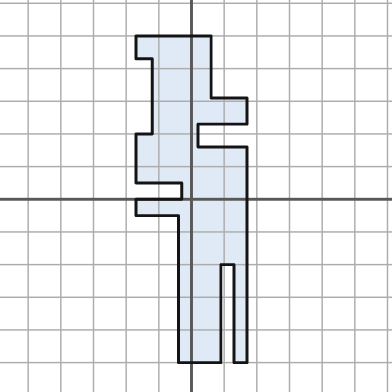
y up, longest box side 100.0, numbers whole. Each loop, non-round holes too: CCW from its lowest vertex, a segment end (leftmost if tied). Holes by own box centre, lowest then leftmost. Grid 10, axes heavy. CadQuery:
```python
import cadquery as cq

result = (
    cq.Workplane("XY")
    .moveTo(-4.0, -50.0)
    .lineTo(9.0, -50.0)
    .lineTo(9.0, -20.0)
    .lineTo(13.0, -20.0)
    .lineTo(13.0, -50.0)
    .lineTo(17.0, -50.0)
    .lineTo(17.0, 16.0)
    .lineTo(2.0, 16.0)
    .lineTo(2.0, 23.0)
    .lineTo(17.0, 23.0)
    .lineTo(17.0, 31.0)
    .lineTo(6.0, 31.0)
    .lineTo(6.0, 50.0)
    .lineTo(-17.0, 50.0)
    .lineTo(-17.0, 43.0)
    .lineTo(-12.0, 43.0)
    .lineTo(-12.0, 20.0)
    .lineTo(-17.0, 20.0)
    .lineTo(-17.0, 5.0)
    .lineTo(-3.0, 5.0)
    .lineTo(-3.0, 0.0)
    .lineTo(-17.0, 0.0)
    .lineTo(-17.0, -5.0)
    .lineTo(-4.0, -5.0)
    .close()
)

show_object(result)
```